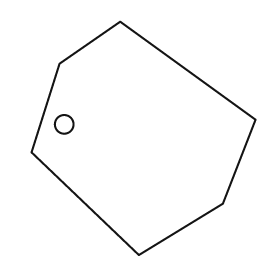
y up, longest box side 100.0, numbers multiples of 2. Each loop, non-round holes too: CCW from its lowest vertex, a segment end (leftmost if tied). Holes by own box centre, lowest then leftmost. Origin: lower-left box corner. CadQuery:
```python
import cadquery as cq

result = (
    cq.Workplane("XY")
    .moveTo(46.0, 0.0)
    .lineTo(82.0, 22.0)
    .lineTo(96.0, 58.0)
    .lineTo(38.0, 100.0)
    .lineTo(12.0, 82.0)
    .lineTo(0.0, 44.0)
    .close()
    .moveTo(14.0, 56.0)
    .circle(4.0)
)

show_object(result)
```